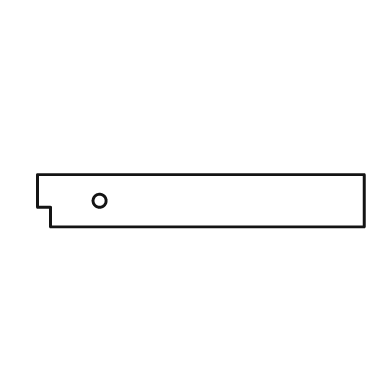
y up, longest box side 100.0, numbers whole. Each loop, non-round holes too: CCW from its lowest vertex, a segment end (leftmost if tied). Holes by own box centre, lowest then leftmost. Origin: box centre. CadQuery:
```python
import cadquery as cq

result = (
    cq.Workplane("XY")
    .moveTo(-46.0, -8.0)
    .lineTo(50.0, -8.0)
    .lineTo(50.0, 8.0)
    .lineTo(-50.0, 8.0)
    .lineTo(-50.0, -2.0)
    .lineTo(-46.0, -2.0)
    .close()
    .moveTo(-31.0, 0.0)
    .circle(2.0)
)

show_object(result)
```